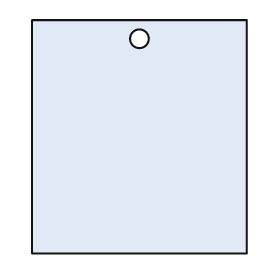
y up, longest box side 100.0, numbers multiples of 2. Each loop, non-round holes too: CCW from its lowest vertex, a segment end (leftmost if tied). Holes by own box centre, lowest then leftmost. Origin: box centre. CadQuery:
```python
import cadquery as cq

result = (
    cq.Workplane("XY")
    .moveTo(-46.0, -50.0)
    .lineTo(46.0, -50.0)
    .lineTo(46.0, 50.0)
    .lineTo(-46.0, 50.0)
    .close()
    .moveTo(0.0, 42.0)
    .circle(4.0)
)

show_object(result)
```